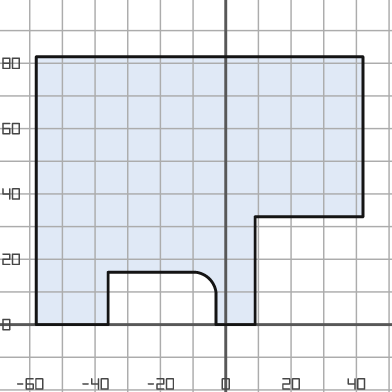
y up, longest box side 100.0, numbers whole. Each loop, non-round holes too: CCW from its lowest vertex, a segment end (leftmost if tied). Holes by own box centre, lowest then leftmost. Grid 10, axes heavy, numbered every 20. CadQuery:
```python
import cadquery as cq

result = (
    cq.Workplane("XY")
    .moveTo(-58.0, 0.0)
    .lineTo(-36.0, 0.0)
    .lineTo(-36.0, 16.0)
    .lineTo(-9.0, 16.0)
    .threePointArc((-5.0, 14.0), (-3.0, 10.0))
    .lineTo(-3.0, 0.0)
    .lineTo(9.0, 0.0)
    .lineTo(9.0, 33.0)
    .lineTo(42.0, 33.0)
    .lineTo(42.0, 82.0)
    .lineTo(-58.0, 82.0)
    .close()
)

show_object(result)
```